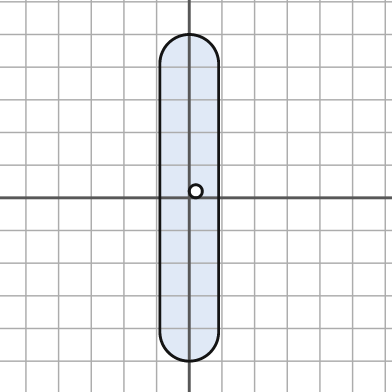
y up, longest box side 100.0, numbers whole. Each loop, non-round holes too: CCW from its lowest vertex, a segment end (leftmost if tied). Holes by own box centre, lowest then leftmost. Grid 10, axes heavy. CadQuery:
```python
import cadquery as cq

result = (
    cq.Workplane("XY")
    .moveTo(-9.0, -41.0)
    .threePointArc((0.0, -50.0), (9.0, -41.0))
    .lineTo(9.0, 41.0)
    .threePointArc((0.0, 50.0), (-9.0, 41.0))
    .close()
    .moveTo(2.0, 2.0)
    .circle(2.0)
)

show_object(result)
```